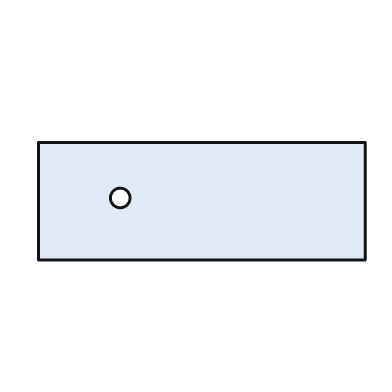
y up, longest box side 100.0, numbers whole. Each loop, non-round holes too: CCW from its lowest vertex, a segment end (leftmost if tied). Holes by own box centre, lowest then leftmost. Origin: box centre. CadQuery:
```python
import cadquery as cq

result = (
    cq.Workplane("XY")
    .moveTo(-50.0, -18.0)
    .lineTo(50.0, -18.0)
    .lineTo(50.0, 18.0)
    .lineTo(-50.0, 18.0)
    .close()
    .moveTo(-25.0, 1.0)
    .circle(3.0)
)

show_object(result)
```